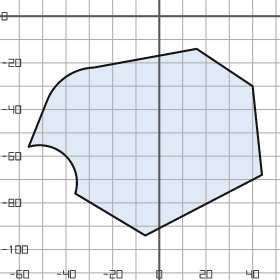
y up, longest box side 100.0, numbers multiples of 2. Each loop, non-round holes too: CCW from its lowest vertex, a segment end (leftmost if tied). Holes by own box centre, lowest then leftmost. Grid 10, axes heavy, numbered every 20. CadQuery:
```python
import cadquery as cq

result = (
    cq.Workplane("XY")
    .moveTo(-6.0, -94.0)
    .lineTo(44.0, -68.0)
    .lineTo(40.0, -30.0)
    .lineTo(16.0, -14.0)
    .lineTo(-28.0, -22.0)
    .threePointArc((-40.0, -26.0), (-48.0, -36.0))
    .lineTo(-56.0, -56.0)
    .threePointArc((-40.0, -60.0), (-36.0, -76.0))
    .close()
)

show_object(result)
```